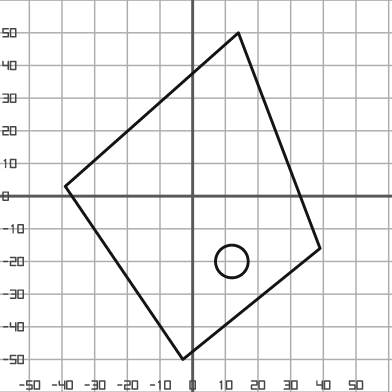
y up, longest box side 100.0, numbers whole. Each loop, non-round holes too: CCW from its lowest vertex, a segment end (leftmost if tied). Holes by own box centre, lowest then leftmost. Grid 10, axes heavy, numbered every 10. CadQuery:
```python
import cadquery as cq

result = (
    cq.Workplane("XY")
    .moveTo(-3.0, -50.0)
    .lineTo(39.0, -16.0)
    .lineTo(14.0, 50.0)
    .lineTo(-39.0, 3.0)
    .close()
    .moveTo(12.0, -20.0)
    .circle(5.0)
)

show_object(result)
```